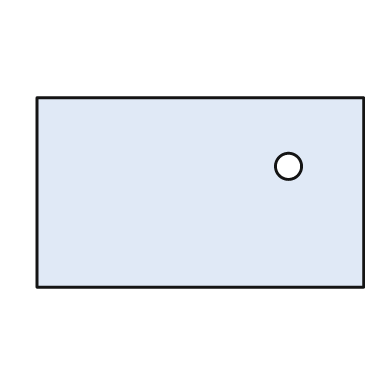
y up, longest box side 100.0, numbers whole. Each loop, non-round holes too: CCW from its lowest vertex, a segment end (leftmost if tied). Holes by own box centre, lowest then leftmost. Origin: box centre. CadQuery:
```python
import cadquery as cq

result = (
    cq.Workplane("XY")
    .moveTo(-50.0, -29.0)
    .lineTo(50.0, -29.0)
    .lineTo(50.0, 29.0)
    .lineTo(-50.0, 29.0)
    .close()
    .moveTo(27.0, 8.0)
    .circle(4.0)
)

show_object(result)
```